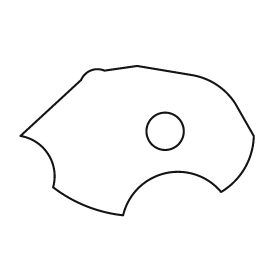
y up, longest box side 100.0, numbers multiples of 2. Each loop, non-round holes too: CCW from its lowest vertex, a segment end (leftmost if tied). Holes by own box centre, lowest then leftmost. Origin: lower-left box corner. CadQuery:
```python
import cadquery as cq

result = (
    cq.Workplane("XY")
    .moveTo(44.0, 0.0)
    .threePointArc((62.0, 18.0), (86.0, 10.0))
    .threePointArc((96.0, 20.0), (100.0, 34.0))
    .lineTo(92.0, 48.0)
    .threePointArc((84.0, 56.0), (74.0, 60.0))
    .lineTo(50.0, 64.0)
    .lineTo(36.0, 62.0)
    .threePointArc((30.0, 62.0), (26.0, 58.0))
    .lineTo(0.0, 34.0)
    .threePointArc((12.0, 26.0), (14.0, 12.0))
    .threePointArc((28.0, 4.0), (44.0, 0.0))
    .close()
    .moveTo(62.0, 36.0)
    .circle(8.0)
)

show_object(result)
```